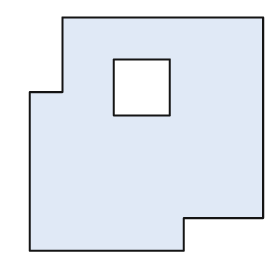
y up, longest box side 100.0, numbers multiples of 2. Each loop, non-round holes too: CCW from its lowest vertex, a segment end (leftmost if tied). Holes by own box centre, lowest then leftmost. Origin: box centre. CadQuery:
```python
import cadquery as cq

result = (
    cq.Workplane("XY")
    .moveTo(-50.0, -50.0)
    .lineTo(16.0, -50.0)
    .lineTo(16.0, -36.0)
    .lineTo(50.0, -36.0)
    .lineTo(50.0, 50.0)
    .lineTo(-36.0, 50.0)
    .lineTo(-36.0, 18.0)
    .lineTo(-50.0, 18.0)
    .close()
    .moveTo(-14.0, 8.0)
    .lineTo(10.0, 8.0)
    .lineTo(10.0, 32.0)
    .lineTo(-14.0, 32.0)
    .close()
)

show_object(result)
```